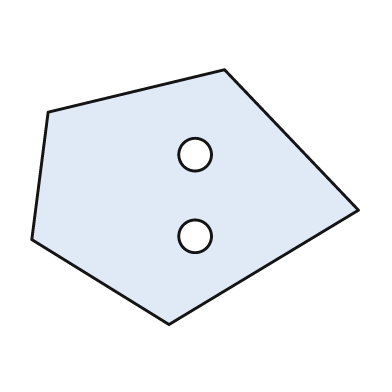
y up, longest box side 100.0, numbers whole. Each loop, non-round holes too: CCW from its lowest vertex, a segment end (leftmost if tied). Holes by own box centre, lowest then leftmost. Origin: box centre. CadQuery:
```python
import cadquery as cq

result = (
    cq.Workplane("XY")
    .moveTo(-8.0, -39.0)
    .lineTo(50.0, -4.0)
    .lineTo(9.0, 39.0)
    .lineTo(-45.0, 26.0)
    .lineTo(-50.0, -13.0)
    .close()
    .moveTo(0.0, -12.0)
    .circle(5.0)
    .moveTo(0.0, 13.0)
    .circle(5.0)
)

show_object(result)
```